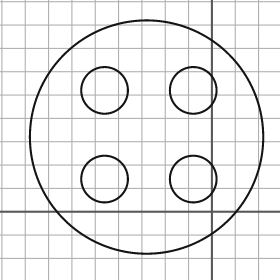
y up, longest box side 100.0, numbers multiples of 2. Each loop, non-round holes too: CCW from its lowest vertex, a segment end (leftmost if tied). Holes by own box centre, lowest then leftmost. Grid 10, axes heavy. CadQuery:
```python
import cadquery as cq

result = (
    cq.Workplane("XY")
    .moveTo(-28.0, 32.0)
    .circle(50.0)
    .moveTo(-46.0, 14.0)
    .circle(10.0)
    .moveTo(-8.0, 14.0)
    .circle(10.0)
    .moveTo(-46.0, 52.0)
    .circle(10.0)
    .moveTo(-8.0, 52.0)
    .circle(10.0)
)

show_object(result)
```